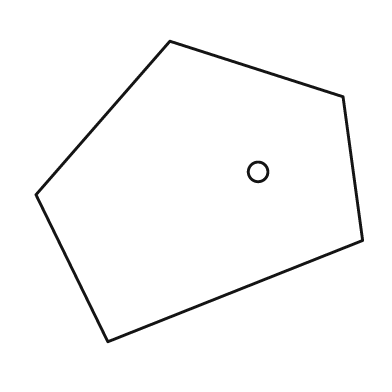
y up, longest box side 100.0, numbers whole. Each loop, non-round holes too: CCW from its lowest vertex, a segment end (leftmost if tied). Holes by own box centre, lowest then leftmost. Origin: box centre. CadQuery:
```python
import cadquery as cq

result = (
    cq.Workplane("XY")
    .moveTo(-28.0, -46.0)
    .lineTo(50.0, -15.0)
    .lineTo(44.0, 29.0)
    .lineTo(-9.0, 46.0)
    .lineTo(-50.0, -1.0)
    .close()
    .moveTo(18.0, 6.0)
    .circle(3.0)
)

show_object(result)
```